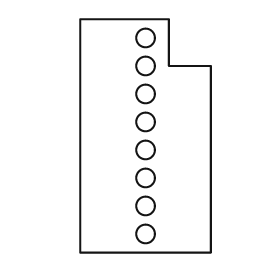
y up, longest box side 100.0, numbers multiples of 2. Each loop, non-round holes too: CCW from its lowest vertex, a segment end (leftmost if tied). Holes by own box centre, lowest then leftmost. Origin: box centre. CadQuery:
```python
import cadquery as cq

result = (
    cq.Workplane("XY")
    .moveTo(-28.0, -50.0)
    .lineTo(28.0, -50.0)
    .lineTo(28.0, 30.0)
    .lineTo(10.0, 30.0)
    .lineTo(10.0, 50.0)
    .lineTo(-28.0, 50.0)
    .close()
    .moveTo(0.0, -42.0)
    .circle(4.0)
    .moveTo(0.0, -30.0)
    .circle(4.0)
    .moveTo(0.0, -18.0)
    .circle(4.0)
    .moveTo(0.0, -6.0)
    .circle(4.0)
    .moveTo(0.0, 6.0)
    .circle(4.0)
    .moveTo(0.0, 18.0)
    .circle(4.0)
    .moveTo(0.0, 30.0)
    .circle(4.0)
    .moveTo(0.0, 42.0)
    .circle(4.0)
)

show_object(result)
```